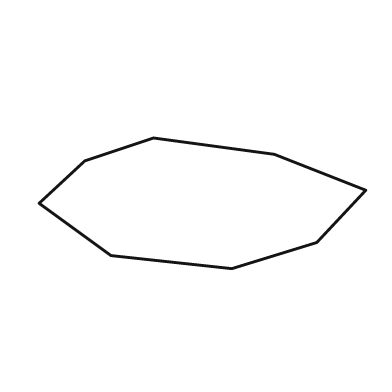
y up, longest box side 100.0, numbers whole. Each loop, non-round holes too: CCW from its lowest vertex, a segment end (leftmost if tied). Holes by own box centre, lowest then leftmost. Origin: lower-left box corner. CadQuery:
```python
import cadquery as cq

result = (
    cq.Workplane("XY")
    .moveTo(59.0, 0.0)
    .lineTo(85.0, 8.0)
    .lineTo(100.0, 24.0)
    .lineTo(72.0, 35.0)
    .lineTo(35.0, 40.0)
    .lineTo(14.0, 33.0)
    .lineTo(0.0, 20.0)
    .lineTo(22.0, 4.0)
    .close()
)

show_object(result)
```